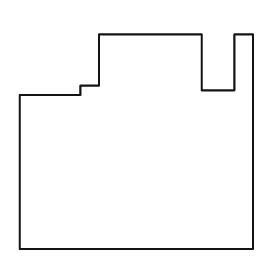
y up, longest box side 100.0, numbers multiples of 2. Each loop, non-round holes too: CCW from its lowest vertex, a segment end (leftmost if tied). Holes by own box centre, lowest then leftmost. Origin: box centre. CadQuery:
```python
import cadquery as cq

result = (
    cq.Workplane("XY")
    .moveTo(-50.0, -46.0)
    .lineTo(50.0, -46.0)
    .lineTo(50.0, 46.0)
    .lineTo(42.0, 46.0)
    .lineTo(42.0, 22.0)
    .lineTo(28.0, 22.0)
    .lineTo(28.0, 46.0)
    .lineTo(-16.0, 46.0)
    .lineTo(-16.0, 24.0)
    .lineTo(-24.0, 24.0)
    .lineTo(-24.0, 20.0)
    .lineTo(-50.0, 20.0)
    .close()
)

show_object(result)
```